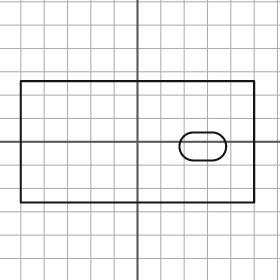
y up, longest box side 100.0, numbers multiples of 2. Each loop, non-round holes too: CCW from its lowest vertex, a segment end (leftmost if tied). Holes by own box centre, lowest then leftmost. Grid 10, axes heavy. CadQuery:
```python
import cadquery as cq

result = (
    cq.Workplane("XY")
    .moveTo(-50.0, -26.0)
    .lineTo(50.0, -26.0)
    .lineTo(50.0, 26.0)
    .lineTo(-50.0, 26.0)
    .close()
    .moveTo(24.0, -8.0)
    .lineTo(32.0, -8.0)
    .threePointArc((38.0, -2.0), (32.0, 4.0))
    .lineTo(24.0, 4.0)
    .threePointArc((18.0, -2.0), (24.0, -8.0))
    .close()
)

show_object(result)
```